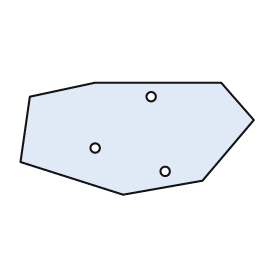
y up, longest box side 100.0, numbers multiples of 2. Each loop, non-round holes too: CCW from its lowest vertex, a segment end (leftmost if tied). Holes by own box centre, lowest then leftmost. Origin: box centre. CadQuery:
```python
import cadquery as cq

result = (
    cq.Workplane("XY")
    .moveTo(-6.0, -24.0)
    .lineTo(28.0, -18.0)
    .lineTo(50.0, 8.0)
    .lineTo(36.0, 24.0)
    .lineTo(-18.0, 24.0)
    .lineTo(-46.0, 18.0)
    .lineTo(-50.0, -10.0)
    .close()
    .moveTo(12.0, -14.0)
    .circle(2.0)
    .moveTo(-18.0, -4.0)
    .circle(2.0)
    .moveTo(6.0, 18.0)
    .circle(2.0)
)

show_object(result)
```